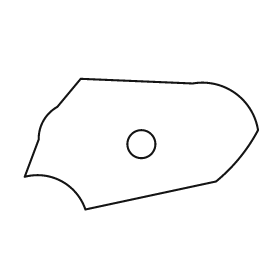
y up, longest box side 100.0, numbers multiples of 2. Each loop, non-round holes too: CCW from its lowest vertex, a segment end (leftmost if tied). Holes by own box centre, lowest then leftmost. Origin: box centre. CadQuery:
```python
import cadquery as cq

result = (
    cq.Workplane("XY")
    .moveTo(-24.0, -28.0)
    .lineTo(32.0, -16.0)
    .threePointArc((42.0, -6.0), (50.0, 6.0))
    .threePointArc((40.0, 22.0), (22.0, 26.0))
    .lineTo(-26.0, 28.0)
    .lineTo(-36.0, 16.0)
    .threePointArc((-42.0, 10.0), (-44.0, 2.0))
    .lineTo(-50.0, -14.0)
    .threePointArc((-34.0, -16.0), (-24.0, -28.0))
    .close()
    .moveTo(0.0, 0.0)
    .circle(6.0)
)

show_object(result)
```